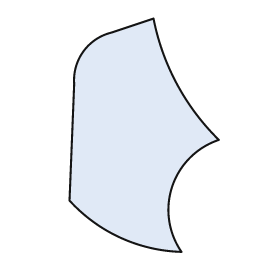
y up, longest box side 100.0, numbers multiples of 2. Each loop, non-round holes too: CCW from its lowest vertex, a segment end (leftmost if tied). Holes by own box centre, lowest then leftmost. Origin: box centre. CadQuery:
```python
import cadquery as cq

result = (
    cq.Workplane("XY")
    .moveTo(16.0, -50.0)
    .threePointArc((12.0, -22.0), (32.0, -2.0))
    .threePointArc((14.0, 22.0), (4.0, 50.0))
    .lineTo(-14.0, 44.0)
    .threePointArc((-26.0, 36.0), (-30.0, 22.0))
    .lineTo(-32.0, -28.0)
    .threePointArc((-10.0, -44.0), (16.0, -50.0))
    .close()
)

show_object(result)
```